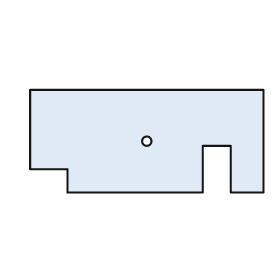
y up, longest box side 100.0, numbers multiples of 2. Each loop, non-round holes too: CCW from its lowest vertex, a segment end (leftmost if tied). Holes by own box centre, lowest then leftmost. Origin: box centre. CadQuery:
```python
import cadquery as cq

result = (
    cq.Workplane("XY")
    .moveTo(-34.0, -22.0)
    .lineTo(24.0, -22.0)
    .lineTo(24.0, -2.0)
    .lineTo(36.0, -2.0)
    .lineTo(36.0, -22.0)
    .lineTo(50.0, -22.0)
    .lineTo(50.0, 22.0)
    .lineTo(-50.0, 22.0)
    .lineTo(-50.0, -12.0)
    .lineTo(-34.0, -12.0)
    .close()
    .moveTo(0.0, 0.0)
    .circle(2.0)
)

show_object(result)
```